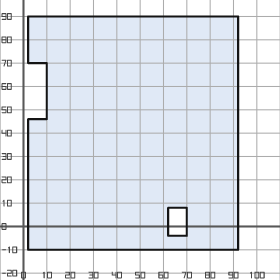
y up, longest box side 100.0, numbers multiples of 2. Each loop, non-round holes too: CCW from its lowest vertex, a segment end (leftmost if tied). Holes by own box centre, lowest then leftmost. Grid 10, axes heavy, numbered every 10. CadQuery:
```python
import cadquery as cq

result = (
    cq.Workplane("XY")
    .moveTo(2.0, -10.0)
    .lineTo(92.0, -10.0)
    .lineTo(92.0, 90.0)
    .lineTo(2.0, 90.0)
    .lineTo(2.0, 70.0)
    .lineTo(10.0, 70.0)
    .lineTo(10.0, 46.0)
    .lineTo(2.0, 46.0)
    .close()
    .moveTo(62.0, -4.0)
    .lineTo(70.0, -4.0)
    .lineTo(70.0, 8.0)
    .lineTo(62.0, 8.0)
    .close()
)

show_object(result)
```